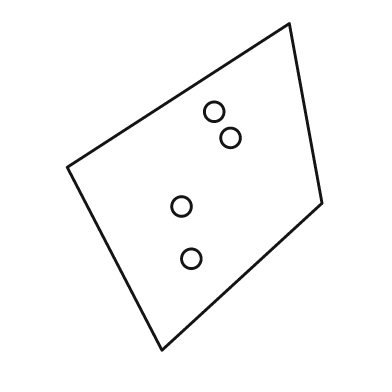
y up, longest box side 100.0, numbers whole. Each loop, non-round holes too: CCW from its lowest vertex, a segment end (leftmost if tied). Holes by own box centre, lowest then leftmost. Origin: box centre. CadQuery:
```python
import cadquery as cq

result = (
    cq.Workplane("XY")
    .moveTo(-10.0, -50.0)
    .lineTo(39.0, -5.0)
    .lineTo(29.0, 50.0)
    .lineTo(-39.0, 6.0)
    .close()
    .moveTo(-1.0, -22.0)
    .circle(3.0)
    .moveTo(-4.0, -6.0)
    .circle(3.0)
    .moveTo(11.0, 15.0)
    .circle(3.0)
    .moveTo(6.0, 23.0)
    .circle(3.0)
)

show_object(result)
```